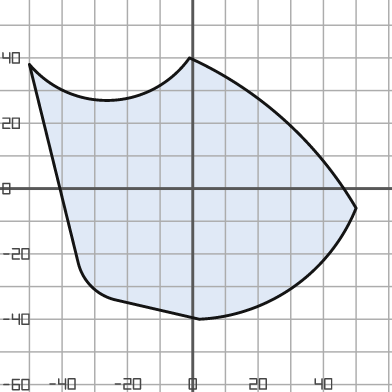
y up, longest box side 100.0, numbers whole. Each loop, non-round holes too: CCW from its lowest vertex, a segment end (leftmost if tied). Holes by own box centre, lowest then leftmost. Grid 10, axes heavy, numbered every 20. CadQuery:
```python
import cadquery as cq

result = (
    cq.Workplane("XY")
    .moveTo(2.0, -40.0)
    .threePointArc((31.0, -30.0), (50.0, -6.0))
    .threePointArc((28.0, 21.0), (-1.0, 40.0))
    .threePointArc((-25.0, 27.0), (-50.0, 38.0))
    .lineTo(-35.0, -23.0)
    .threePointArc((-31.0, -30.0), (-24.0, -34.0))
    .close()
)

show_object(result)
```